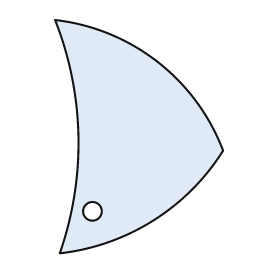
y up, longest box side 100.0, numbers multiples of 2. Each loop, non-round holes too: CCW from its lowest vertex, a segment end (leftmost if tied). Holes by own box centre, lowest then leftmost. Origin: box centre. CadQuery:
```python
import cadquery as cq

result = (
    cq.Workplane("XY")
    .moveTo(-34.0, -50.0)
    .threePointArc((6.0, -36.0), (36.0, -6.0))
    .threePointArc((8.0, 32.0), (-36.0, 50.0))
    .threePointArc((-26.0, 0.0), (-34.0, -50.0))
    .close()
    .moveTo(-20.0, -32.0)
    .circle(4.0)
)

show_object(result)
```